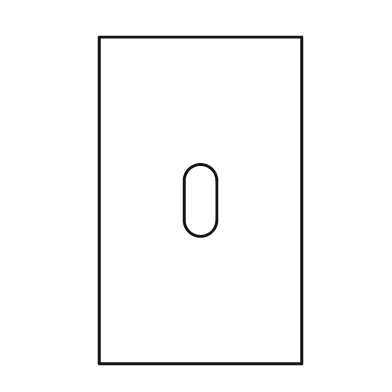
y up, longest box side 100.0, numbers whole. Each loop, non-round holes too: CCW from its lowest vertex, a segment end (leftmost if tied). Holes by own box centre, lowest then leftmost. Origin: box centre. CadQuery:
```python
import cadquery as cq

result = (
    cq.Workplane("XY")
    .moveTo(-31.0, -50.0)
    .lineTo(31.0, -50.0)
    .lineTo(31.0, 50.0)
    .lineTo(-31.0, 50.0)
    .close()
    .moveTo(-5.0, -6.0)
    .threePointArc((0.0, -11.0), (5.0, -6.0))
    .lineTo(5.0, 6.0)
    .threePointArc((0.0, 11.0), (-5.0, 6.0))
    .close()
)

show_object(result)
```